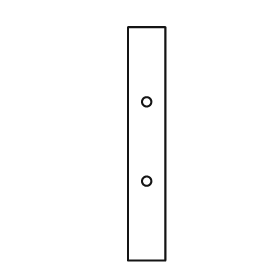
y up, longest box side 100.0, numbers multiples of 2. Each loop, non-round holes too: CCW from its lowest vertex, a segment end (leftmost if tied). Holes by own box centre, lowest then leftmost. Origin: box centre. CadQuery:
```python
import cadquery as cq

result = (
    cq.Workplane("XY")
    .moveTo(-8.0, -50.0)
    .lineTo(8.0, -50.0)
    .lineTo(8.0, 50.0)
    .lineTo(-8.0, 50.0)
    .close()
    .moveTo(0.0, -16.0)
    .circle(2.0)
    .moveTo(0.0, 18.0)
    .circle(2.0)
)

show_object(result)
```